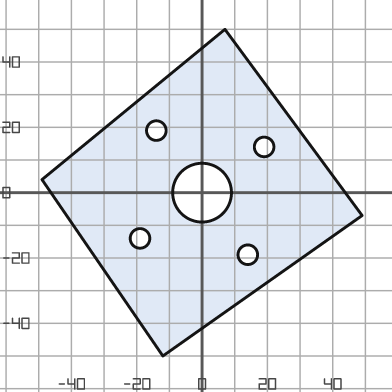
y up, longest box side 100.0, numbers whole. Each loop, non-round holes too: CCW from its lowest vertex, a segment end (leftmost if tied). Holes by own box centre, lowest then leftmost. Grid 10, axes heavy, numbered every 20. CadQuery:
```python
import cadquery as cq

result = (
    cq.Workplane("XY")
    .moveTo(-12.0, -50.0)
    .lineTo(49.0, -7.0)
    .lineTo(7.0, 50.0)
    .lineTo(-49.0, 4.0)
    .close()
    .moveTo(14.0, -19.0)
    .circle(3.0)
    .moveTo(-19.0, -14.0)
    .circle(3.0)
    .moveTo(0.0, 0.0)
    .circle(9.0)
    .moveTo(19.0, 14.0)
    .circle(3.0)
    .moveTo(-14.0, 19.0)
    .circle(3.0)
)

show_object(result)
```